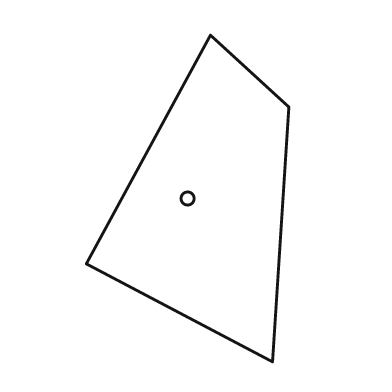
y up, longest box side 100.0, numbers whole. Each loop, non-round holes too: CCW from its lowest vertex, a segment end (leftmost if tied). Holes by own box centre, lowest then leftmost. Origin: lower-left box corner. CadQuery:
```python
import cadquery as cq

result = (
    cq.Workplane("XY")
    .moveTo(57.0, 0.0)
    .lineTo(62.0, 78.0)
    .lineTo(38.0, 100.0)
    .lineTo(0.0, 30.0)
    .close()
    .moveTo(31.0, 50.0)
    .circle(2.0)
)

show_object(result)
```